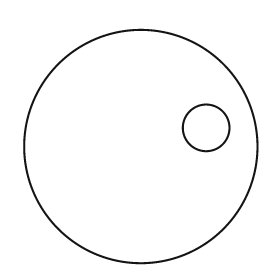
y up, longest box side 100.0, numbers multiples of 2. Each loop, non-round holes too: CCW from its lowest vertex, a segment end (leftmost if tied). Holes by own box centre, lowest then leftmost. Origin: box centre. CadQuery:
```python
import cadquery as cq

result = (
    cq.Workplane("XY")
    .moveTo(0.0, 0.0)
    .circle(50.0)
    .moveTo(28.0, 8.0)
    .circle(10.0)
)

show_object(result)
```